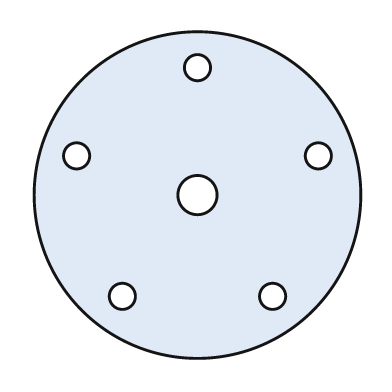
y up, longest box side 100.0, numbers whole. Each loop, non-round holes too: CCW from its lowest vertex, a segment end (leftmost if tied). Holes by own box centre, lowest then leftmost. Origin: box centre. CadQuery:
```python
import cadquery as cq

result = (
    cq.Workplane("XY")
    .moveTo(0.0, 0.0)
    .circle(50.0)
    .moveTo(-23.0, -31.0)
    .circle(4.0)
    .moveTo(23.0, -31.0)
    .circle(4.0)
    .moveTo(0.0, 0.0)
    .circle(6.0)
    .moveTo(-37.0, 12.0)
    .circle(4.0)
    .moveTo(37.0, 12.0)
    .circle(4.0)
    .moveTo(0.0, 39.0)
    .circle(4.0)
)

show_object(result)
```